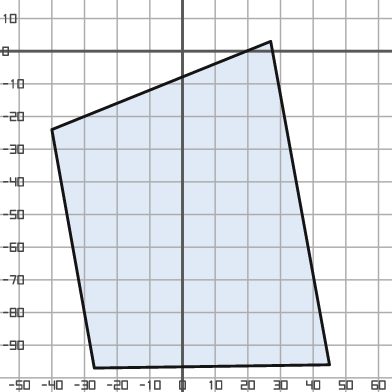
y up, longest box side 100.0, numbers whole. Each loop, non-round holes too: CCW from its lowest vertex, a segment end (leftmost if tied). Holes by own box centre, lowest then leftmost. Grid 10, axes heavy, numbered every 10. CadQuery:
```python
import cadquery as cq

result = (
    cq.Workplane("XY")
    .moveTo(-27.0, -97.0)
    .lineTo(45.0, -96.0)
    .lineTo(27.0, 3.0)
    .lineTo(-40.0, -24.0)
    .close()
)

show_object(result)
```